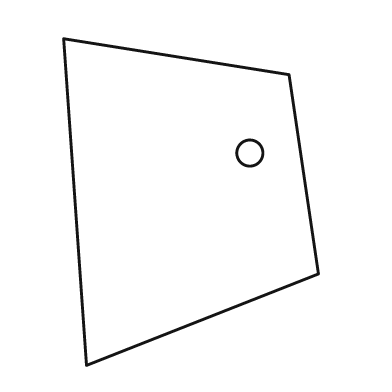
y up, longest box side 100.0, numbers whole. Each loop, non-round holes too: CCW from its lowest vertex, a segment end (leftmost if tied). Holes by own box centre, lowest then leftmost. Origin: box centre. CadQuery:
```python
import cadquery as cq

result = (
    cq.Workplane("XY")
    .moveTo(-32.0, -50.0)
    .lineTo(39.0, -22.0)
    .lineTo(30.0, 39.0)
    .lineTo(-39.0, 50.0)
    .close()
    .moveTo(18.0, 15.0)
    .circle(4.0)
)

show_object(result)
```